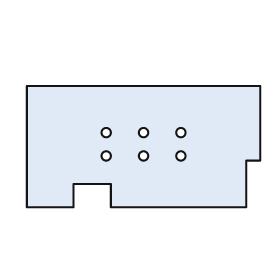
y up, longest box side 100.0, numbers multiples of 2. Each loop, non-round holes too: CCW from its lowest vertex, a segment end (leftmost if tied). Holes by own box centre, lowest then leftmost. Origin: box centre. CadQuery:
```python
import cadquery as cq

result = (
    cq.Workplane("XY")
    .moveTo(-50.0, -26.0)
    .lineTo(-30.0, -26.0)
    .lineTo(-30.0, -16.0)
    .lineTo(-14.0, -16.0)
    .lineTo(-14.0, -26.0)
    .lineTo(44.0, -26.0)
    .lineTo(44.0, -6.0)
    .lineTo(50.0, -6.0)
    .lineTo(50.0, 26.0)
    .lineTo(-50.0, 26.0)
    .close()
    .moveTo(-16.0, -4.0)
    .circle(2.0)
    .moveTo(0.0, -4.0)
    .circle(2.0)
    .moveTo(16.0, -4.0)
    .circle(2.0)
    .moveTo(-16.0, 6.0)
    .circle(2.0)
    .moveTo(0.0, 6.0)
    .circle(2.0)
    .moveTo(16.0, 6.0)
    .circle(2.0)
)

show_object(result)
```